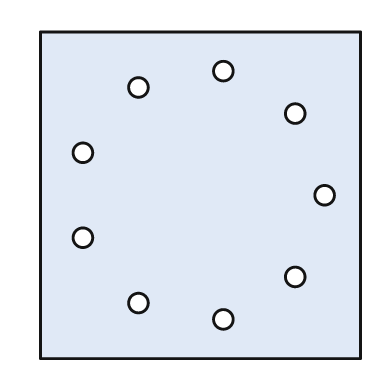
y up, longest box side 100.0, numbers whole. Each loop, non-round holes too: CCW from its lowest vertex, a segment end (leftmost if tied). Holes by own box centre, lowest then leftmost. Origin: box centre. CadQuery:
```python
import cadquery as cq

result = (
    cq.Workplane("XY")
    .moveTo(-49.0, -50.0)
    .lineTo(49.0, -50.0)
    .lineTo(49.0, 50.0)
    .lineTo(-49.0, 50.0)
    .close()
    .moveTo(7.0, -38.0)
    .circle(3.0)
    .moveTo(-19.0, -33.0)
    .circle(3.0)
    .moveTo(29.0, -25.0)
    .circle(3.0)
    .moveTo(-36.0, -13.0)
    .circle(3.0)
    .moveTo(38.0, 0.0)
    .circle(3.0)
    .moveTo(-36.0, 13.0)
    .circle(3.0)
    .moveTo(29.0, 25.0)
    .circle(3.0)
    .moveTo(-19.0, 33.0)
    .circle(3.0)
    .moveTo(7.0, 38.0)
    .circle(3.0)
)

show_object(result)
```